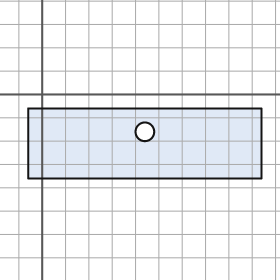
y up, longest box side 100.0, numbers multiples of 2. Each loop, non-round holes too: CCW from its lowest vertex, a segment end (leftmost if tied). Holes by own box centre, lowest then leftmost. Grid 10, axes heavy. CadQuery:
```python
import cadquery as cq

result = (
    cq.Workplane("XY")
    .moveTo(-6.0, -36.0)
    .lineTo(94.0, -36.0)
    .lineTo(94.0, -6.0)
    .lineTo(-6.0, -6.0)
    .close()
    .moveTo(44.0, -16.0)
    .circle(4.0)
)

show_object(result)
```